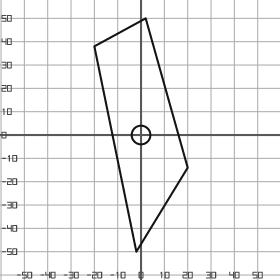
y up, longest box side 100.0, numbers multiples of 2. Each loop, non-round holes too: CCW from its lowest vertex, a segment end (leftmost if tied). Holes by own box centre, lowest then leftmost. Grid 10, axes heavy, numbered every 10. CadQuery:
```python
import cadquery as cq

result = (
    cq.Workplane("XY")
    .moveTo(-2.0, -50.0)
    .lineTo(20.0, -14.0)
    .lineTo(2.0, 50.0)
    .lineTo(-20.0, 38.0)
    .close()
    .moveTo(0.0, 0.0)
    .circle(4.0)
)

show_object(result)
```